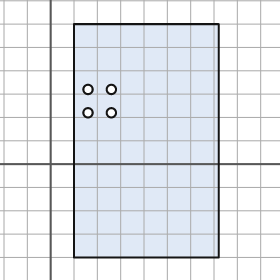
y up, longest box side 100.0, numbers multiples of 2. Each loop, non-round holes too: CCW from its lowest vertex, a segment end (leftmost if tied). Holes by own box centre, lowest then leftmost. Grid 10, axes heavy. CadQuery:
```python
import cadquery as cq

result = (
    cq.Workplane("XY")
    .moveTo(10.0, -40.0)
    .lineTo(72.0, -40.0)
    .lineTo(72.0, 60.0)
    .lineTo(10.0, 60.0)
    .close()
    .moveTo(16.0, 22.0)
    .circle(2.0)
    .moveTo(26.0, 22.0)
    .circle(2.0)
    .moveTo(16.0, 32.0)
    .circle(2.0)
    .moveTo(26.0, 32.0)
    .circle(2.0)
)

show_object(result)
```